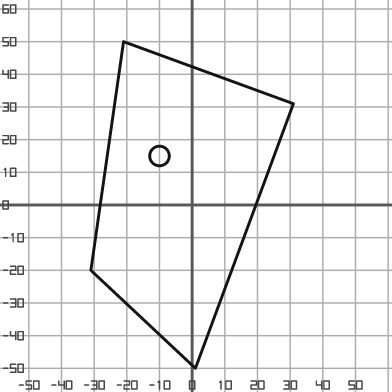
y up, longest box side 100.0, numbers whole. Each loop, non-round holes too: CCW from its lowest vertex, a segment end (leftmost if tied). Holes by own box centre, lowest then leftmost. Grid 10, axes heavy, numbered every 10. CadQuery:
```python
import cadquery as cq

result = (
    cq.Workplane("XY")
    .moveTo(1.0, -50.0)
    .lineTo(31.0, 31.0)
    .lineTo(-21.0, 50.0)
    .lineTo(-31.0, -20.0)
    .close()
    .moveTo(-10.0, 15.0)
    .circle(3.0)
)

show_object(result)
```